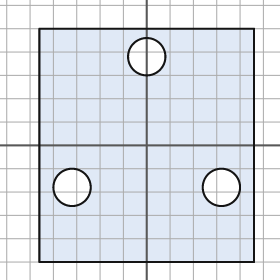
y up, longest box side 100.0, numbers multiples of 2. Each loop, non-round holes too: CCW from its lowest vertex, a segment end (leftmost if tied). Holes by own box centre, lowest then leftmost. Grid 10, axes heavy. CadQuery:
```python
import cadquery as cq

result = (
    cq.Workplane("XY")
    .moveTo(-46.0, -50.0)
    .lineTo(46.0, -50.0)
    .lineTo(46.0, 50.0)
    .lineTo(-46.0, 50.0)
    .close()
    .moveTo(-32.0, -18.0)
    .circle(8.0)
    .moveTo(32.0, -18.0)
    .circle(8.0)
    .moveTo(0.0, 38.0)
    .circle(8.0)
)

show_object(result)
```